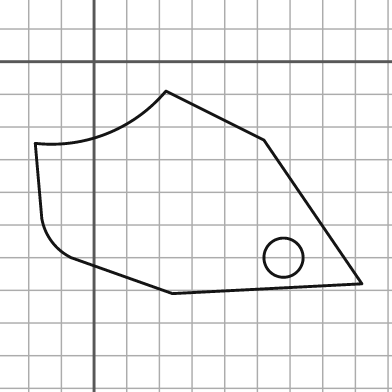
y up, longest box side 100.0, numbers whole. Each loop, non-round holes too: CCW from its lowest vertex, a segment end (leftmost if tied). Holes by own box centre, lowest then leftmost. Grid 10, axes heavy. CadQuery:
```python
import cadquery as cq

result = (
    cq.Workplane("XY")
    .moveTo(24.0, -71.0)
    .lineTo(82.0, -68.0)
    .lineTo(52.0, -24.0)
    .lineTo(22.0, -9.0)
    .threePointArc((4.0, -22.0), (-18.0, -25.0))
    .lineTo(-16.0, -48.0)
    .threePointArc((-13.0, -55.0), (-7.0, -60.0))
    .close()
    .moveTo(58.0, -60.0)
    .circle(6.0)
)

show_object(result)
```